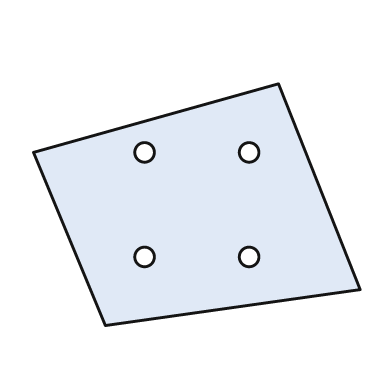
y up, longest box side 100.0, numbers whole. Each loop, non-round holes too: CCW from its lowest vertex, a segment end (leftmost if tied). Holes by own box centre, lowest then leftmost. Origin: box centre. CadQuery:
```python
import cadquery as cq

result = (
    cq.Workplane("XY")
    .moveTo(-28.0, -37.0)
    .lineTo(50.0, -26.0)
    .lineTo(25.0, 37.0)
    .lineTo(-50.0, 16.0)
    .close()
    .moveTo(-16.0, -16.0)
    .circle(3.0)
    .moveTo(16.0, -16.0)
    .circle(3.0)
    .moveTo(-16.0, 16.0)
    .circle(3.0)
    .moveTo(16.0, 16.0)
    .circle(3.0)
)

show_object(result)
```